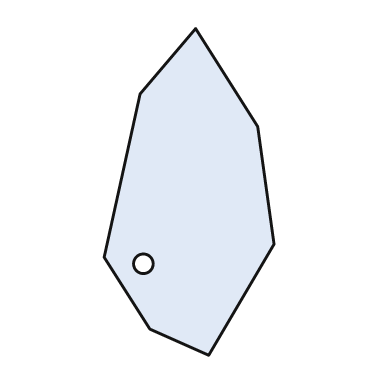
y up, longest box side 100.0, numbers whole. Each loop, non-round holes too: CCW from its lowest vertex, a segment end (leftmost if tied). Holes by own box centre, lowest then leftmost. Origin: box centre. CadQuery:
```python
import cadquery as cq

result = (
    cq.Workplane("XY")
    .moveTo(6.0, -50.0)
    .lineTo(26.0, -16.0)
    .lineTo(21.0, 20.0)
    .lineTo(2.0, 50.0)
    .lineTo(-15.0, 30.0)
    .lineTo(-26.0, -20.0)
    .lineTo(-12.0, -42.0)
    .close()
    .moveTo(-14.0, -22.0)
    .circle(3.0)
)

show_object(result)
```